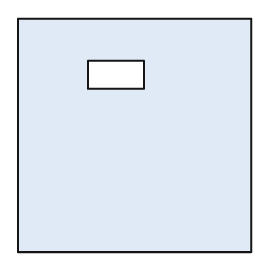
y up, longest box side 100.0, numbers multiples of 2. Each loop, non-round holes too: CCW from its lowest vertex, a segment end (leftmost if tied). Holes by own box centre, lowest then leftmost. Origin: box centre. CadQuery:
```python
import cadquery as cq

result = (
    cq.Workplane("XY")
    .moveTo(-50.0, -50.0)
    .lineTo(50.0, -50.0)
    .lineTo(50.0, 50.0)
    .lineTo(-50.0, 50.0)
    .close()
    .moveTo(-20.0, 20.0)
    .lineTo(4.0, 20.0)
    .lineTo(4.0, 32.0)
    .lineTo(-20.0, 32.0)
    .close()
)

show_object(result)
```